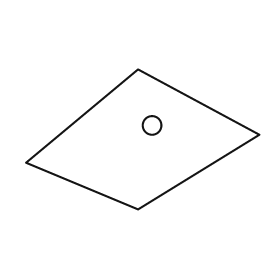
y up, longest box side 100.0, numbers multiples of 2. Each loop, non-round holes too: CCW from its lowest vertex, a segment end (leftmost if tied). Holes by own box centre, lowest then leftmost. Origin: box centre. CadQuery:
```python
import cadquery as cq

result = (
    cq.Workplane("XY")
    .moveTo(-2.0, -30.0)
    .lineTo(50.0, 2.0)
    .lineTo(-2.0, 30.0)
    .lineTo(-50.0, -10.0)
    .close()
    .moveTo(4.0, 6.0)
    .circle(4.0)
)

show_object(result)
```